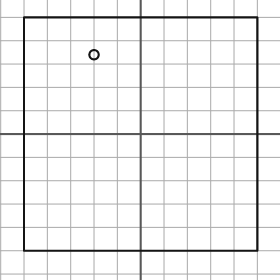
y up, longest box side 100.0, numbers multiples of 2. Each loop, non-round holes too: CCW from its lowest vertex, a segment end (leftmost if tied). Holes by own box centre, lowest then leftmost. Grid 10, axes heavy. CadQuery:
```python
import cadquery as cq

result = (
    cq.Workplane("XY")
    .moveTo(-50.0, -50.0)
    .lineTo(50.0, -50.0)
    .lineTo(50.0, 50.0)
    .lineTo(-50.0, 50.0)
    .close()
    .moveTo(-20.0, 34.0)
    .circle(2.0)
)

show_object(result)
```